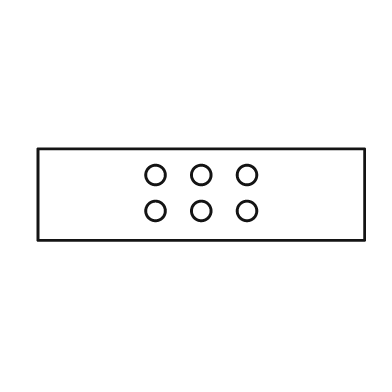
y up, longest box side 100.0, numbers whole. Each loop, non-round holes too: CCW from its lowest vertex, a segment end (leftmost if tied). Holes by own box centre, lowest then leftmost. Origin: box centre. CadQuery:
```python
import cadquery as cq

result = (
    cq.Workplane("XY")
    .moveTo(-50.0, -14.0)
    .lineTo(50.0, -14.0)
    .lineTo(50.0, 14.0)
    .lineTo(-50.0, 14.0)
    .close()
    .moveTo(-14.0, -5.0)
    .circle(3.0)
    .moveTo(0.0, -5.0)
    .circle(3.0)
    .moveTo(14.0, -5.0)
    .circle(3.0)
    .moveTo(-14.0, 6.0)
    .circle(3.0)
    .moveTo(0.0, 6.0)
    .circle(3.0)
    .moveTo(14.0, 6.0)
    .circle(3.0)
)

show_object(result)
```